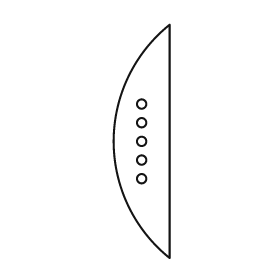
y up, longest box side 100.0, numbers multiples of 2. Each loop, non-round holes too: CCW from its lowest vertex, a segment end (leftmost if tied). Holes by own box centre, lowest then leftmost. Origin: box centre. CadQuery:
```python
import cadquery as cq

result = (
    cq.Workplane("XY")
    .moveTo(12.0, -50.0)
    .lineTo(12.0, 50.0)
    .threePointArc((-12.0, 0.0), (12.0, -50.0))
    .close()
    .moveTo(0.0, -16.0)
    .circle(2.0)
    .moveTo(0.0, -8.0)
    .circle(2.0)
    .moveTo(0.0, 0.0)
    .circle(2.0)
    .moveTo(0.0, 8.0)
    .circle(2.0)
    .moveTo(0.0, 16.0)
    .circle(2.0)
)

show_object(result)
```